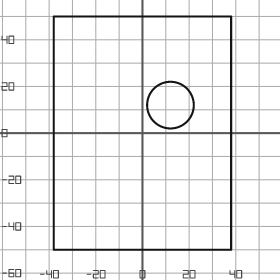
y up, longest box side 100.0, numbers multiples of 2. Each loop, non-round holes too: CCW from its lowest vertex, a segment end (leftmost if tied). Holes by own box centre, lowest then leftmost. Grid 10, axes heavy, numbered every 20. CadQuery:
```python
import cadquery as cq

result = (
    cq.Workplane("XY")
    .moveTo(-38.0, -50.0)
    .lineTo(38.0, -50.0)
    .lineTo(38.0, 50.0)
    .lineTo(-38.0, 50.0)
    .close()
    .moveTo(12.0, 12.0)
    .circle(10.0)
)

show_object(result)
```